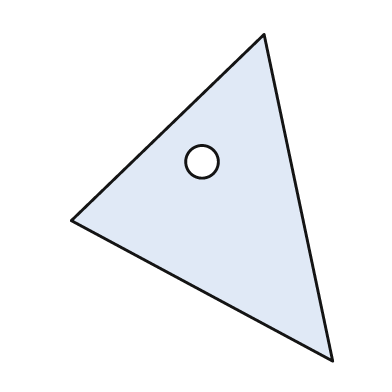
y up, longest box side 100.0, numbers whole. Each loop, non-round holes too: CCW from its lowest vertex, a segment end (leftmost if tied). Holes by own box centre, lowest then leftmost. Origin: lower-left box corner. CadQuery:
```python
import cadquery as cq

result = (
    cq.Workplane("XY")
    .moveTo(80.0, 0.0)
    .lineTo(59.0, 100.0)
    .lineTo(0.0, 43.0)
    .close()
    .moveTo(40.0, 61.0)
    .circle(5.0)
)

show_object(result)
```